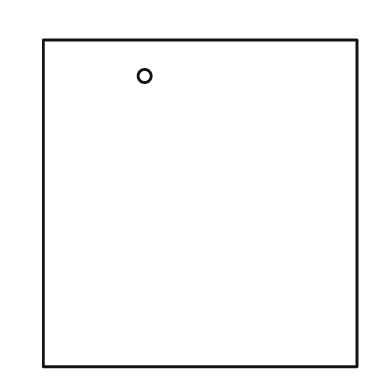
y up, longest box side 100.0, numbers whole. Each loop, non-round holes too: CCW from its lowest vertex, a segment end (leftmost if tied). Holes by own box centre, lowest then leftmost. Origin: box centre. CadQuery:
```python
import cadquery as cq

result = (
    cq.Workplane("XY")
    .moveTo(-48.0, -50.0)
    .lineTo(48.0, -50.0)
    .lineTo(48.0, 50.0)
    .lineTo(-48.0, 50.0)
    .close()
    .moveTo(-17.0, 39.0)
    .circle(2.0)
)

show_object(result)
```